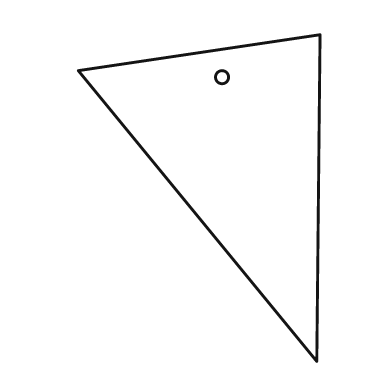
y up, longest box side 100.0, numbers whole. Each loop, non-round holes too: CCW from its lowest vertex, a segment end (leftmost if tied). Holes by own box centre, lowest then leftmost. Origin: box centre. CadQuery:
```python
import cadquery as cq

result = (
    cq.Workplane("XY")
    .moveTo(36.0, -50.0)
    .lineTo(37.0, 50.0)
    .lineTo(-37.0, 39.0)
    .close()
    .moveTo(7.0, 37.0)
    .circle(2.0)
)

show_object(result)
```